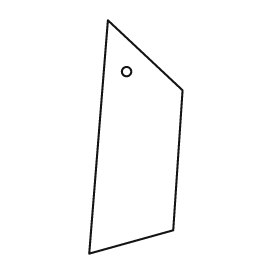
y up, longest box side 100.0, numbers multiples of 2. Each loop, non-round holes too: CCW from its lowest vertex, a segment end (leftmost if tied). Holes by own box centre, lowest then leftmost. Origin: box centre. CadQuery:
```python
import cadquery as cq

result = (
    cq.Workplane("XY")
    .moveTo(-20.0, -50.0)
    .lineTo(16.0, -40.0)
    .lineTo(20.0, 20.0)
    .lineTo(-12.0, 50.0)
    .close()
    .moveTo(-4.0, 28.0)
    .circle(2.0)
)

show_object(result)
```